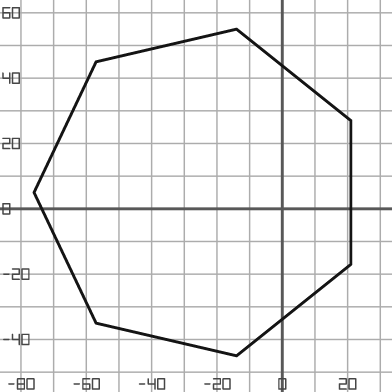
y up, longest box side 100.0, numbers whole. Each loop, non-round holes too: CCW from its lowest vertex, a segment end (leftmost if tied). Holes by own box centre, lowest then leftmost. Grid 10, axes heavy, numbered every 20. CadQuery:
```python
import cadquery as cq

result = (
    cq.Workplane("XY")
    .moveTo(-14.0, -45.0)
    .lineTo(21.0, -17.0)
    .lineTo(21.0, 27.0)
    .lineTo(-14.0, 55.0)
    .lineTo(-57.0, 45.0)
    .lineTo(-76.0, 5.0)
    .lineTo(-57.0, -35.0)
    .close()
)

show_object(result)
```